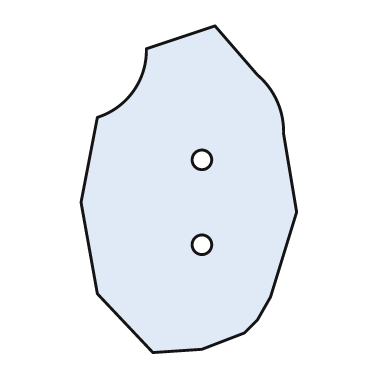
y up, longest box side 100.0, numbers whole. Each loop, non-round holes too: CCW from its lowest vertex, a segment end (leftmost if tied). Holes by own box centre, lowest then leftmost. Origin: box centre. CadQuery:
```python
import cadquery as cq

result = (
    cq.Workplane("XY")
    .moveTo(-11.0, -50.0)
    .lineTo(4.0, -49.0)
    .lineTo(17.0, -44.0)
    .lineTo(21.0, -40.0)
    .lineTo(25.0, -33.0)
    .lineTo(33.0, -7.0)
    .lineTo(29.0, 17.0)
    .threePointArc((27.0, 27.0), (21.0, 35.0))
    .lineTo(8.0, 50.0)
    .lineTo(-13.0, 43.0)
    .threePointArc((-17.0, 30.0), (-28.0, 22.0))
    .lineTo(-33.0, -4.0)
    .lineTo(-28.0, -32.0)
    .close()
    .moveTo(4.0, -17.0)
    .circle(3.0)
    .moveTo(4.0, 9.0)
    .circle(3.0)
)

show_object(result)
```